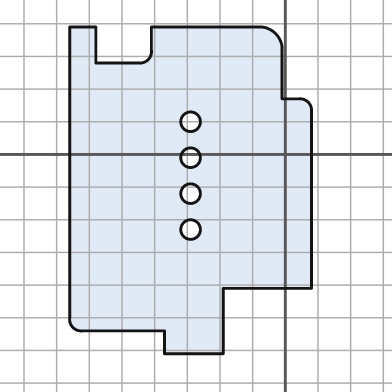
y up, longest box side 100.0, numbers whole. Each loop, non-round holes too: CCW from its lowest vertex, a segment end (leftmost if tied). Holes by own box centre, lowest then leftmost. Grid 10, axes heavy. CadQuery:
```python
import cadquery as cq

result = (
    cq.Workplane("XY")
    .moveTo(-37.0, -61.0)
    .lineTo(-19.0, -61.0)
    .lineTo(-19.0, -41.0)
    .lineTo(8.0, -41.0)
    .lineTo(8.0, 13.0)
    .threePointArc((7.0, 16.0), (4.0, 17.0))
    .lineTo(-1.0, 17.0)
    .lineTo(-1.0, 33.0)
    .threePointArc((-3.0, 37.0), (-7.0, 39.0))
    .lineTo(-41.0, 39.0)
    .lineTo(-41.0, 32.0)
    .threePointArc((-42.0, 29.0), (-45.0, 28.0))
    .lineTo(-58.0, 28.0)
    .lineTo(-58.0, 39.0)
    .lineTo(-66.0, 39.0)
    .lineTo(-66.0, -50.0)
    .threePointArc((-65.0, -53.0), (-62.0, -54.0))
    .lineTo(-37.0, -54.0)
    .close()
    .moveTo(-29.0, -23.0)
    .circle(3.0)
    .moveTo(-29.0, -12.0)
    .circle(3.0)
    .moveTo(-29.0, -1.0)
    .circle(3.0)
    .moveTo(-29.0, 10.0)
    .circle(3.0)
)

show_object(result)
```